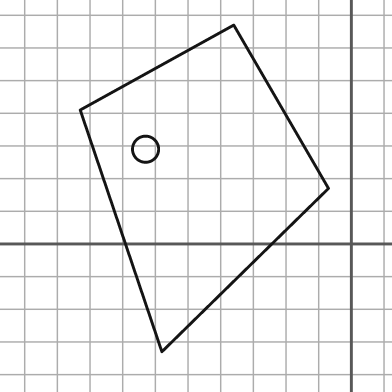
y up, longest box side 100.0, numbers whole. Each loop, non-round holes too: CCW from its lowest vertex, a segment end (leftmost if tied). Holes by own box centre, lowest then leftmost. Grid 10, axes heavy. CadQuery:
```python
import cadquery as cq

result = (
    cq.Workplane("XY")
    .moveTo(-58.0, -33.0)
    .lineTo(-7.0, 17.0)
    .lineTo(-36.0, 67.0)
    .lineTo(-83.0, 41.0)
    .close()
    .moveTo(-63.0, 29.0)
    .circle(4.0)
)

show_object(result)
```